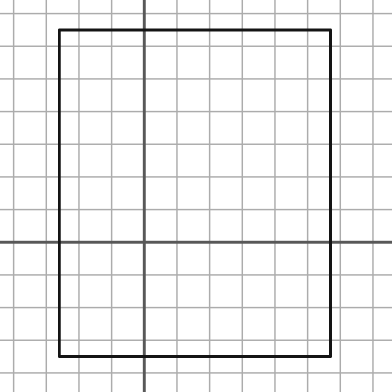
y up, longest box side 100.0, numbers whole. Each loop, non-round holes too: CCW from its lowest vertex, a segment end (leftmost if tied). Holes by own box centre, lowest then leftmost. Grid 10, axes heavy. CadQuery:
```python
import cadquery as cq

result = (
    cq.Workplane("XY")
    .moveTo(-26.0, -35.0)
    .lineTo(57.0, -35.0)
    .lineTo(57.0, 65.0)
    .lineTo(-26.0, 65.0)
    .close()
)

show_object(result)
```